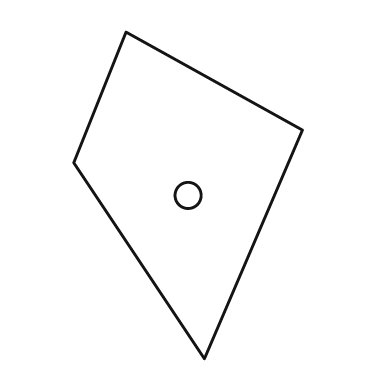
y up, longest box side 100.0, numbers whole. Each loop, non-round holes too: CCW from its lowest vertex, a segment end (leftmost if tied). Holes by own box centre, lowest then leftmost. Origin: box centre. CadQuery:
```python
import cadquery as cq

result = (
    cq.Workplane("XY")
    .moveTo(5.0, -50.0)
    .lineTo(35.0, 20.0)
    .lineTo(-19.0, 50.0)
    .lineTo(-35.0, 10.0)
    .close()
    .moveTo(0.0, 0.0)
    .circle(4.0)
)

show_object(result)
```